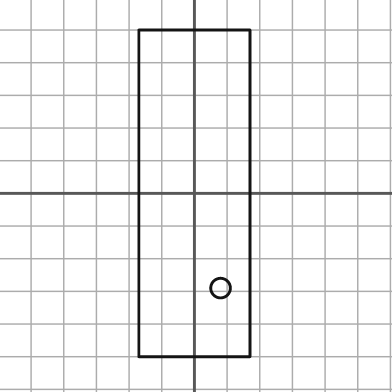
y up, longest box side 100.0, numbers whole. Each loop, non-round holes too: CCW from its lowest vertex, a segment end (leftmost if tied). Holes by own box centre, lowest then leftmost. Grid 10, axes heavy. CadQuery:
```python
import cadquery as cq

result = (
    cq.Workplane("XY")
    .moveTo(-17.0, -50.0)
    .lineTo(17.0, -50.0)
    .lineTo(17.0, 50.0)
    .lineTo(-17.0, 50.0)
    .close()
    .moveTo(8.0, -29.0)
    .circle(3.0)
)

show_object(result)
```